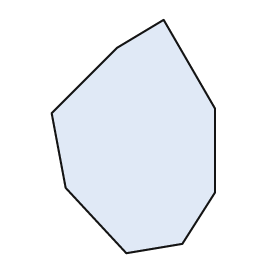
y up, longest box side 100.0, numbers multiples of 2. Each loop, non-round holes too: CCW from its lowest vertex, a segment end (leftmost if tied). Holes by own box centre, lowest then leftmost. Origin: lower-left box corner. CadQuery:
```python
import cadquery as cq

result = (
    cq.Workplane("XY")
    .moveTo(32.0, 0.0)
    .lineTo(56.0, 4.0)
    .lineTo(70.0, 26.0)
    .lineTo(70.0, 62.0)
    .lineTo(48.0, 100.0)
    .lineTo(28.0, 88.0)
    .lineTo(0.0, 60.0)
    .lineTo(6.0, 28.0)
    .close()
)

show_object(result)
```